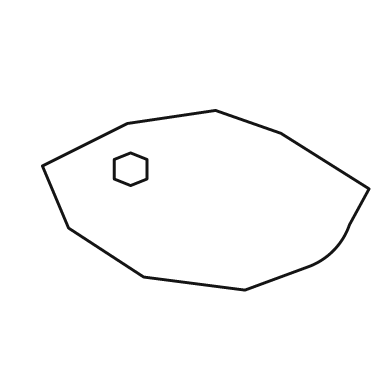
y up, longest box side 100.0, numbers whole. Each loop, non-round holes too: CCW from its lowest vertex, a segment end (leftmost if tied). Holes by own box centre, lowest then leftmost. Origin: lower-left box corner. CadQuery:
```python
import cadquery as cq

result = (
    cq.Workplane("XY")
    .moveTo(62.0, 0.0)
    .lineTo(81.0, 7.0)
    .threePointArc((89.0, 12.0), (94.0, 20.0))
    .lineTo(100.0, 31.0)
    .lineTo(73.0, 48.0)
    .lineTo(53.0, 55.0)
    .lineTo(26.0, 51.0)
    .lineTo(0.0, 38.0)
    .lineTo(8.0, 19.0)
    .lineTo(31.0, 4.0)
    .close()
    .moveTo(27.0, 32.0)
    .lineTo(32.0, 34.0)
    .lineTo(32.0, 40.0)
    .lineTo(27.0, 42.0)
    .lineTo(22.0, 40.0)
    .lineTo(22.0, 34.0)
    .close()
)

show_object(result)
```